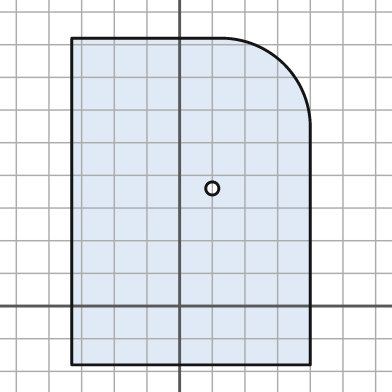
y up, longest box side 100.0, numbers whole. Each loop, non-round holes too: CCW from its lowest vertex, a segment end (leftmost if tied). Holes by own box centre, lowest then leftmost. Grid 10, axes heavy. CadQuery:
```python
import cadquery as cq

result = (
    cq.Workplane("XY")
    .moveTo(-33.0, -18.0)
    .lineTo(40.0, -18.0)
    .lineTo(40.0, 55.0)
    .threePointArc((32.0, 74.0), (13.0, 82.0))
    .lineTo(-33.0, 82.0)
    .close()
    .moveTo(10.0, 36.0)
    .circle(2.0)
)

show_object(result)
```